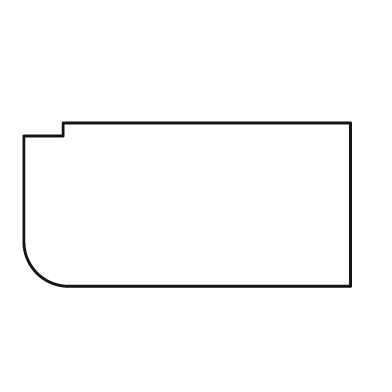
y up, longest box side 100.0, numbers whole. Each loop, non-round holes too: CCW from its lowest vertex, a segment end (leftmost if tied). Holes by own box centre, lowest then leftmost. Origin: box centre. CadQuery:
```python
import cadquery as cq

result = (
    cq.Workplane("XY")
    .moveTo(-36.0, -25.0)
    .lineTo(50.0, -25.0)
    .lineTo(50.0, 25.0)
    .lineTo(-38.0, 25.0)
    .lineTo(-38.0, 21.0)
    .lineTo(-50.0, 21.0)
    .lineTo(-50.0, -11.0)
    .threePointArc((-46.0, -21.0), (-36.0, -25.0))
    .close()
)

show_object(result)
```